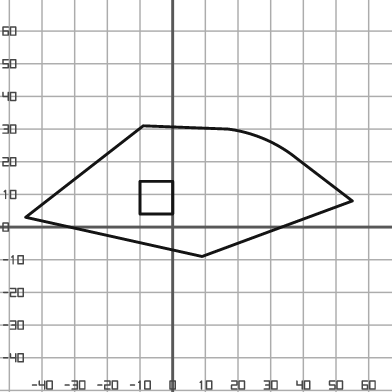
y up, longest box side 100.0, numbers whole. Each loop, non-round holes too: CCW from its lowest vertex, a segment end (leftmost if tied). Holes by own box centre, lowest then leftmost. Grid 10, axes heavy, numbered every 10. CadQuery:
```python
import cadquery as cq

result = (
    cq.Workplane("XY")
    .moveTo(9.0, -9.0)
    .lineTo(55.0, 8.0)
    .lineTo(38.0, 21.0)
    .threePointArc((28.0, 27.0), (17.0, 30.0))
    .lineTo(-9.0, 31.0)
    .lineTo(-45.0, 3.0)
    .close()
    .moveTo(-10.0, 4.0)
    .lineTo(0.0, 4.0)
    .lineTo(0.0, 14.0)
    .lineTo(-10.0, 14.0)
    .close()
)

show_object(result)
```